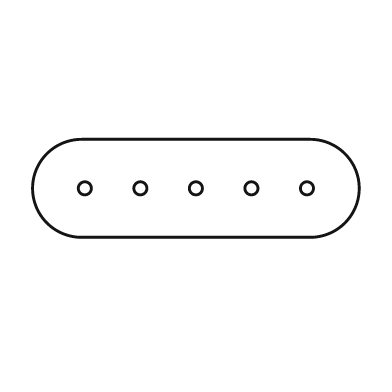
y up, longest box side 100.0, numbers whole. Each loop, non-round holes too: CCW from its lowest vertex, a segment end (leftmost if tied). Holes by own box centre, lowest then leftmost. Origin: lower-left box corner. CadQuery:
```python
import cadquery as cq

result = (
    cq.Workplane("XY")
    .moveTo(15.0, 0.0)
    .lineTo(85.0, 0.0)
    .threePointArc((100.0, 15.0), (85.0, 30.0))
    .lineTo(15.0, 30.0)
    .threePointArc((0.0, 15.0), (15.0, 0.0))
    .close()
    .moveTo(16.0, 15.0)
    .circle(2.0)
    .moveTo(33.0, 15.0)
    .circle(2.0)
    .moveTo(50.0, 15.0)
    .circle(2.0)
    .moveTo(67.0, 15.0)
    .circle(2.0)
    .moveTo(84.0, 15.0)
    .circle(2.0)
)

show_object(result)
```